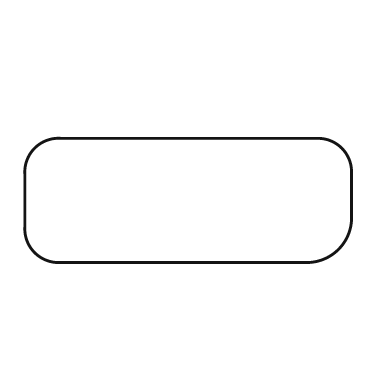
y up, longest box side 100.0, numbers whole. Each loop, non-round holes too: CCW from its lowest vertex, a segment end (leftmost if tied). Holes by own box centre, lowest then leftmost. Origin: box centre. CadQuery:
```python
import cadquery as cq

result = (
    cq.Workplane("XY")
    .moveTo(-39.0, -19.0)
    .lineTo(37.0, -19.0)
    .threePointArc((46.0, -15.0), (50.0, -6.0))
    .lineTo(50.0, 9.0)
    .threePointArc((47.0, 16.0), (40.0, 19.0))
    .lineTo(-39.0, 19.0)
    .threePointArc((-47.0, 16.0), (-50.0, 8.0))
    .lineTo(-50.0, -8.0)
    .threePointArc((-47.0, -16.0), (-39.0, -19.0))
    .close()
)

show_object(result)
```